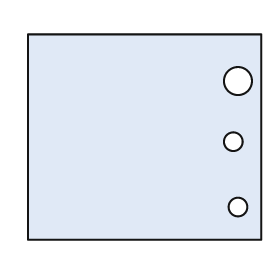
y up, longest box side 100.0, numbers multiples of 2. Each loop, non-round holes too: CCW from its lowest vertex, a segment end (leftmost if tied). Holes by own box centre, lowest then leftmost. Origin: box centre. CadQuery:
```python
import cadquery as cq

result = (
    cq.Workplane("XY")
    .moveTo(-50.0, -44.0)
    .lineTo(50.0, -44.0)
    .lineTo(50.0, 44.0)
    .lineTo(-50.0, 44.0)
    .close()
    .moveTo(40.0, -30.0)
    .circle(4.0)
    .moveTo(38.0, -2.0)
    .circle(4.0)
    .moveTo(40.0, 24.0)
    .circle(6.0)
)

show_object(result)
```